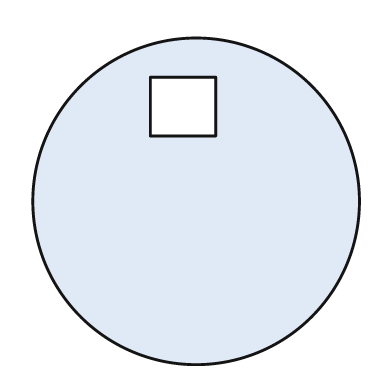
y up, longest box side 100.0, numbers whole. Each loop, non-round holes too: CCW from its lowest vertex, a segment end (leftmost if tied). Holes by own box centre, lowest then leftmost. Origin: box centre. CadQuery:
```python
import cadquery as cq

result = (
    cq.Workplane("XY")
    .moveTo(0.0, 0.0)
    .circle(50.0)
    .moveTo(-14.0, 20.0)
    .lineTo(6.0, 20.0)
    .lineTo(6.0, 38.0)
    .lineTo(-14.0, 38.0)
    .close()
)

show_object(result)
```